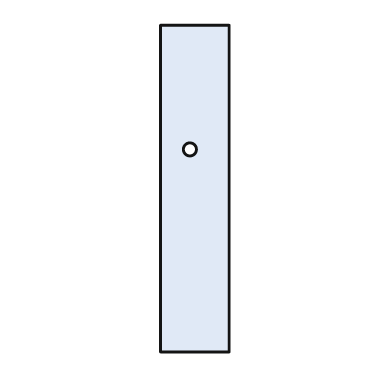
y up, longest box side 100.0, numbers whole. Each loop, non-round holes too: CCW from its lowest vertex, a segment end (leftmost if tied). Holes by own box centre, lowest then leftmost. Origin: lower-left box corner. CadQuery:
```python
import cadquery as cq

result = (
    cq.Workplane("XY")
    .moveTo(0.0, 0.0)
    .lineTo(21.0, 0.0)
    .lineTo(21.0, 100.0)
    .lineTo(0.0, 100.0)
    .close()
    .moveTo(9.0, 62.0)
    .circle(2.0)
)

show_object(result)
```